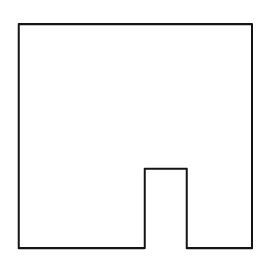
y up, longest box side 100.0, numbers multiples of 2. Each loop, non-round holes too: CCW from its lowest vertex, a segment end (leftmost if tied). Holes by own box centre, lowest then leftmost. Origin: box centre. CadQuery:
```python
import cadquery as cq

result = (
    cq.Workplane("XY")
    .moveTo(-50.0, -48.0)
    .lineTo(4.0, -48.0)
    .lineTo(4.0, -14.0)
    .lineTo(22.0, -14.0)
    .lineTo(22.0, -48.0)
    .lineTo(50.0, -48.0)
    .lineTo(50.0, 48.0)
    .lineTo(-50.0, 48.0)
    .close()
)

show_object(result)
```